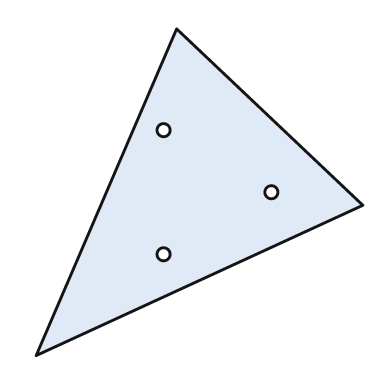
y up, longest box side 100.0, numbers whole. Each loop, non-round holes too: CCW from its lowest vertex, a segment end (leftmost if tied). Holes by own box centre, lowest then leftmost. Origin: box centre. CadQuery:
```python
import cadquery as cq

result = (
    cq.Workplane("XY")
    .moveTo(-50.0, -50.0)
    .lineTo(50.0, -4.0)
    .lineTo(-7.0, 50.0)
    .close()
    .moveTo(-11.0, -19.0)
    .circle(2.0)
    .moveTo(22.0, 0.0)
    .circle(2.0)
    .moveTo(-11.0, 19.0)
    .circle(2.0)
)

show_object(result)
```